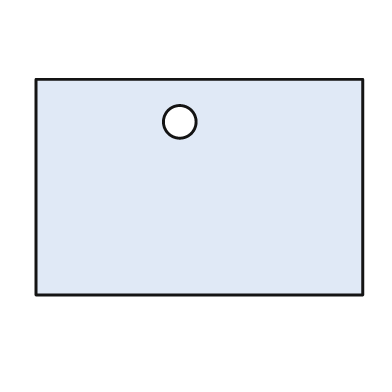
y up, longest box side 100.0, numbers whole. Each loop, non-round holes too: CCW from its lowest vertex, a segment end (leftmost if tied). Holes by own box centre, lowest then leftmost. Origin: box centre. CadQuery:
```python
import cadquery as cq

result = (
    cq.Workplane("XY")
    .moveTo(-50.0, -33.0)
    .lineTo(50.0, -33.0)
    .lineTo(50.0, 33.0)
    .lineTo(-50.0, 33.0)
    .close()
    .moveTo(-6.0, 20.0)
    .circle(5.0)
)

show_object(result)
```